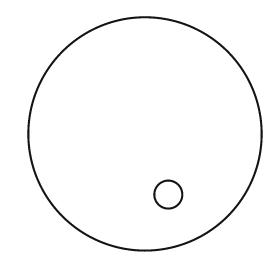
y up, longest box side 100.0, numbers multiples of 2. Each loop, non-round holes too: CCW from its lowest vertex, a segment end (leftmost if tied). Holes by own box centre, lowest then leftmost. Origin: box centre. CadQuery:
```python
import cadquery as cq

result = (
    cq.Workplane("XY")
    .moveTo(0.0, 0.0)
    .circle(50.0)
    .moveTo(10.0, -26.0)
    .circle(6.0)
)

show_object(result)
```